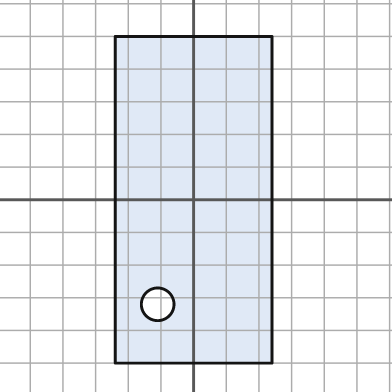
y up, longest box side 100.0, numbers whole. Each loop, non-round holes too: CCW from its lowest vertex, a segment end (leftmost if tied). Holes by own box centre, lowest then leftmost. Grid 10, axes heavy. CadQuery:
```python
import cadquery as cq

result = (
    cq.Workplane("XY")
    .moveTo(-24.0, -50.0)
    .lineTo(24.0, -50.0)
    .lineTo(24.0, 50.0)
    .lineTo(-24.0, 50.0)
    .close()
    .moveTo(-11.0, -32.0)
    .circle(5.0)
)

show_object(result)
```